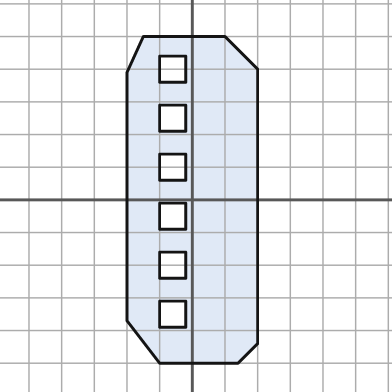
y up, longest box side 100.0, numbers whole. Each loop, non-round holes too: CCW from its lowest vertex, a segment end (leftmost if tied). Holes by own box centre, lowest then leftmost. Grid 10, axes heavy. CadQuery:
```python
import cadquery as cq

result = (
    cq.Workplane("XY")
    .moveTo(-10.0, -50.0)
    .lineTo(14.0, -50.0)
    .lineTo(20.0, -44.0)
    .lineTo(20.0, 40.0)
    .lineTo(10.0, 50.0)
    .lineTo(-15.0, 50.0)
    .lineTo(-20.0, 39.0)
    .lineTo(-20.0, -37.0)
    .close()
    .moveTo(-10.0, -39.0)
    .lineTo(-2.0, -39.0)
    .lineTo(-2.0, -31.0)
    .lineTo(-10.0, -31.0)
    .close()
    .moveTo(-10.0, -24.0)
    .lineTo(-2.0, -24.0)
    .lineTo(-2.0, -16.0)
    .lineTo(-10.0, -16.0)
    .close()
    .moveTo(-10.0, -9.0)
    .lineTo(-2.0, -9.0)
    .lineTo(-2.0, -1.0)
    .lineTo(-10.0, -1.0)
    .close()
    .moveTo(-10.0, 6.0)
    .lineTo(-2.0, 6.0)
    .lineTo(-2.0, 14.0)
    .lineTo(-10.0, 14.0)
    .close()
    .moveTo(-10.0, 21.0)
    .lineTo(-2.0, 21.0)
    .lineTo(-2.0, 29.0)
    .lineTo(-10.0, 29.0)
    .close()
    .moveTo(-10.0, 36.0)
    .lineTo(-2.0, 36.0)
    .lineTo(-2.0, 44.0)
    .lineTo(-10.0, 44.0)
    .close()
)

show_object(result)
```